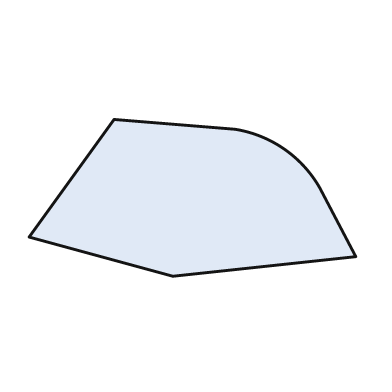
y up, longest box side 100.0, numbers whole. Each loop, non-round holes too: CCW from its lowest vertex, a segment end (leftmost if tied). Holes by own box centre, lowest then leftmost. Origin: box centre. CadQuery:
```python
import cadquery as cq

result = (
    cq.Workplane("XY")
    .moveTo(-6.0, -24.0)
    .lineTo(50.0, -18.0)
    .lineTo(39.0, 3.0)
    .threePointArc((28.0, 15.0), (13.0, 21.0))
    .lineTo(-24.0, 24.0)
    .lineTo(-50.0, -12.0)
    .close()
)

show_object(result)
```